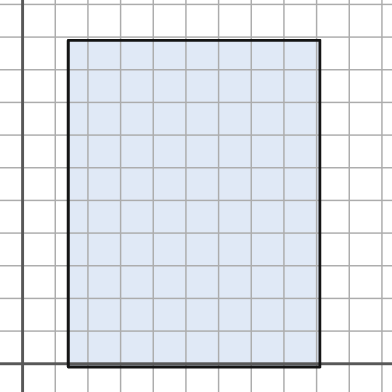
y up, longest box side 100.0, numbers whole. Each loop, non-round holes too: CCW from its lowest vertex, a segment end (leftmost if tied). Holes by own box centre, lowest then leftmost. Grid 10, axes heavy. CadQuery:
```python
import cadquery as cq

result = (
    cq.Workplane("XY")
    .moveTo(14.0, -1.0)
    .lineTo(91.0, -1.0)
    .lineTo(91.0, 99.0)
    .lineTo(14.0, 99.0)
    .close()
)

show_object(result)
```